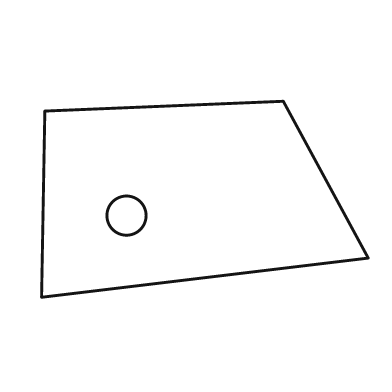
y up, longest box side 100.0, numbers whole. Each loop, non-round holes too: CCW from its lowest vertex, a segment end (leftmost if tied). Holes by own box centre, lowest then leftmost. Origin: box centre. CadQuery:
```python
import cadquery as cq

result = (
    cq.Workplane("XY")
    .moveTo(-50.0, -30.0)
    .lineTo(50.0, -18.0)
    .lineTo(24.0, 30.0)
    .lineTo(-49.0, 27.0)
    .close()
    .moveTo(-24.0, -5.0)
    .circle(6.0)
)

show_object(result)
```